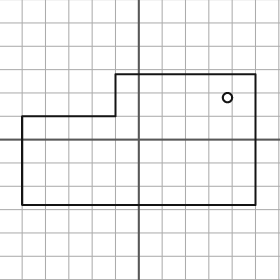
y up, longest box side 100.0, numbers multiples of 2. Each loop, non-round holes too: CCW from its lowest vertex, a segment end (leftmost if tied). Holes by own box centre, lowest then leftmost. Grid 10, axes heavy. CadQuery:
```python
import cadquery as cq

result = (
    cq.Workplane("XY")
    .moveTo(-50.0, -28.0)
    .lineTo(50.0, -28.0)
    .lineTo(50.0, 28.0)
    .lineTo(-10.0, 28.0)
    .lineTo(-10.0, 10.0)
    .lineTo(-50.0, 10.0)
    .close()
    .moveTo(38.0, 18.0)
    .circle(2.0)
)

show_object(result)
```